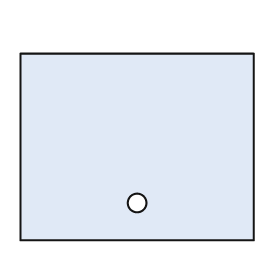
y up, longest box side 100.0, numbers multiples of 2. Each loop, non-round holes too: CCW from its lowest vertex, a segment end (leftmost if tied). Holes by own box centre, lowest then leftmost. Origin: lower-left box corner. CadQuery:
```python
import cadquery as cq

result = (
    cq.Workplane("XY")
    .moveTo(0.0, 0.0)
    .lineTo(100.0, 0.0)
    .lineTo(100.0, 80.0)
    .lineTo(0.0, 80.0)
    .close()
    .moveTo(50.0, 16.0)
    .circle(4.0)
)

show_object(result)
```